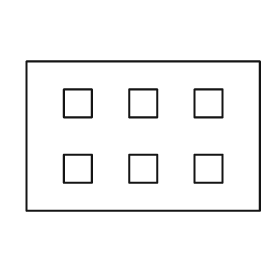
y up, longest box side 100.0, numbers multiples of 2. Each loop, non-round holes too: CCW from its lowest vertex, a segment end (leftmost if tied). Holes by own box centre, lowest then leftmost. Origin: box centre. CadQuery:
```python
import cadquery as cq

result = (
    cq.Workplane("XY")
    .moveTo(-50.0, -32.0)
    .lineTo(50.0, -32.0)
    .lineTo(50.0, 32.0)
    .lineTo(-50.0, 32.0)
    .close()
    .moveTo(-34.0, -20.0)
    .lineTo(-22.0, -20.0)
    .lineTo(-22.0, -8.0)
    .lineTo(-34.0, -8.0)
    .close()
    .moveTo(-6.0, -20.0)
    .lineTo(6.0, -20.0)
    .lineTo(6.0, -8.0)
    .lineTo(-6.0, -8.0)
    .close()
    .moveTo(22.0, -20.0)
    .lineTo(34.0, -20.0)
    .lineTo(34.0, -8.0)
    .lineTo(22.0, -8.0)
    .close()
    .moveTo(-34.0, 8.0)
    .lineTo(-22.0, 8.0)
    .lineTo(-22.0, 20.0)
    .lineTo(-34.0, 20.0)
    .close()
    .moveTo(-6.0, 8.0)
    .lineTo(6.0, 8.0)
    .lineTo(6.0, 20.0)
    .lineTo(-6.0, 20.0)
    .close()
    .moveTo(22.0, 8.0)
    .lineTo(34.0, 8.0)
    .lineTo(34.0, 20.0)
    .lineTo(22.0, 20.0)
    .close()
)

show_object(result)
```